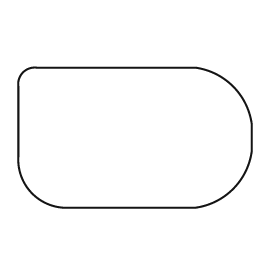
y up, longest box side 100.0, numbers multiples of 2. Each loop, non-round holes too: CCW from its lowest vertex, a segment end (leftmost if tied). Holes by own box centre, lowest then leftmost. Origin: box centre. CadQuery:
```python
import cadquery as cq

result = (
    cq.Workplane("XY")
    .moveTo(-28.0, -30.0)
    .lineTo(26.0, -30.0)
    .threePointArc((42.0, -22.0), (50.0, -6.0))
    .lineTo(50.0, 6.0)
    .threePointArc((42.0, 22.0), (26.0, 30.0))
    .lineTo(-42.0, 30.0)
    .threePointArc((-48.0, 28.0), (-50.0, 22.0))
    .lineTo(-50.0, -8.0)
    .threePointArc((-44.0, -24.0), (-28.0, -30.0))
    .close()
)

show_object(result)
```